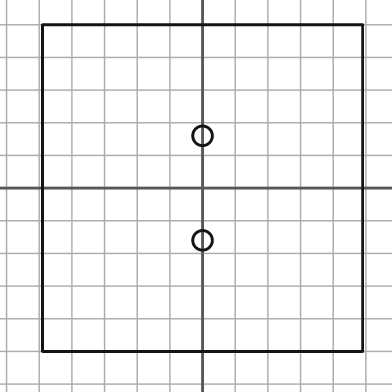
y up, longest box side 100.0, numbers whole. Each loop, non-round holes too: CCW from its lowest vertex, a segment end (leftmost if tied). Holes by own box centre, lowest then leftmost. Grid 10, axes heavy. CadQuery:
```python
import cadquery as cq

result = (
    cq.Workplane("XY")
    .moveTo(-49.0, -50.0)
    .lineTo(49.0, -50.0)
    .lineTo(49.0, 50.0)
    .lineTo(-49.0, 50.0)
    .close()
    .moveTo(0.0, -16.0)
    .circle(3.0)
    .moveTo(0.0, 16.0)
    .circle(3.0)
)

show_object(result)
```